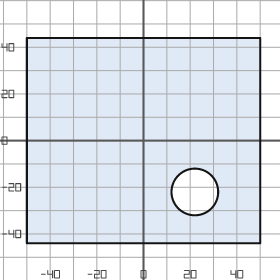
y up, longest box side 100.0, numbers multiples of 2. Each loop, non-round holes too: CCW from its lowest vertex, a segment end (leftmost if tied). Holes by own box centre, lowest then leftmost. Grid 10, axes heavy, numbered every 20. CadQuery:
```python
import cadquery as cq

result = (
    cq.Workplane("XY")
    .moveTo(-50.0, -44.0)
    .lineTo(50.0, -44.0)
    .lineTo(50.0, 44.0)
    .lineTo(-50.0, 44.0)
    .close()
    .moveTo(22.0, -22.0)
    .circle(10.0)
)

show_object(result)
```